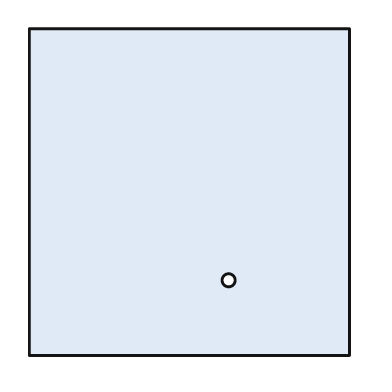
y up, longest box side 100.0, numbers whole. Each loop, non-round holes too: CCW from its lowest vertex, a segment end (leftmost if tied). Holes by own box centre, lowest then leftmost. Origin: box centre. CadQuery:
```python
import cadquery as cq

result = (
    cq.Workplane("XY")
    .moveTo(-49.0, -50.0)
    .lineTo(49.0, -50.0)
    .lineTo(49.0, 50.0)
    .lineTo(-49.0, 50.0)
    .close()
    .moveTo(12.0, -27.0)
    .circle(2.0)
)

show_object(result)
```